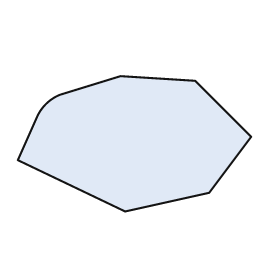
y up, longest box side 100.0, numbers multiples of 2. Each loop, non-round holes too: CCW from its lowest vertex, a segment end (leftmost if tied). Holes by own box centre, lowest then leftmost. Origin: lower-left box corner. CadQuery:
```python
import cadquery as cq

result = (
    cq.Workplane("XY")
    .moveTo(46.0, 0.0)
    .lineTo(82.0, 8.0)
    .lineTo(100.0, 32.0)
    .lineTo(76.0, 56.0)
    .lineTo(44.0, 58.0)
    .lineTo(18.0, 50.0)
    .threePointArc((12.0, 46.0), (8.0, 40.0))
    .lineTo(0.0, 22.0)
    .close()
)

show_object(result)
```